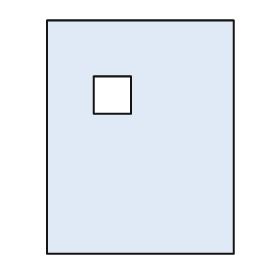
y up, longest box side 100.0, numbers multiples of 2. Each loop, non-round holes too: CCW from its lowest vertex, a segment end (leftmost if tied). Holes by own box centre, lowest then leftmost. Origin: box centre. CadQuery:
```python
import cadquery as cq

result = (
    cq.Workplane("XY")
    .moveTo(-40.0, -50.0)
    .lineTo(40.0, -50.0)
    .lineTo(40.0, 50.0)
    .lineTo(-40.0, 50.0)
    .close()
    .moveTo(-20.0, 10.0)
    .lineTo(-4.0, 10.0)
    .lineTo(-4.0, 26.0)
    .lineTo(-20.0, 26.0)
    .close()
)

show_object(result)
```